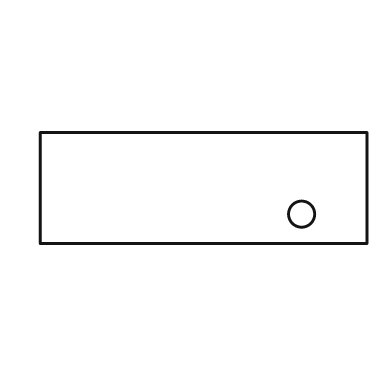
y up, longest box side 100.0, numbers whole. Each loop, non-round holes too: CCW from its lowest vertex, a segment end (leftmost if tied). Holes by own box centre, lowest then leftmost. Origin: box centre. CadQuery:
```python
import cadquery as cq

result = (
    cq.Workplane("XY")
    .moveTo(-50.0, -17.0)
    .lineTo(50.0, -17.0)
    .lineTo(50.0, 17.0)
    .lineTo(-50.0, 17.0)
    .close()
    .moveTo(30.0, -8.0)
    .circle(4.0)
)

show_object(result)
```